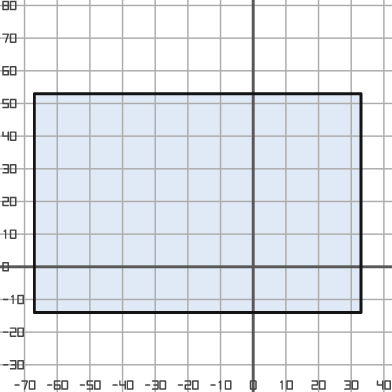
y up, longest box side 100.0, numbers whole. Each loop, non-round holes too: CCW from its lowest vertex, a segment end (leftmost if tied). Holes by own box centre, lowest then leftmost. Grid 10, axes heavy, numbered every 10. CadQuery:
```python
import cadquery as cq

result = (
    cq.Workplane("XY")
    .moveTo(-67.0, -14.0)
    .lineTo(33.0, -14.0)
    .lineTo(33.0, 53.0)
    .lineTo(-67.0, 53.0)
    .close()
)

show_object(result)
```